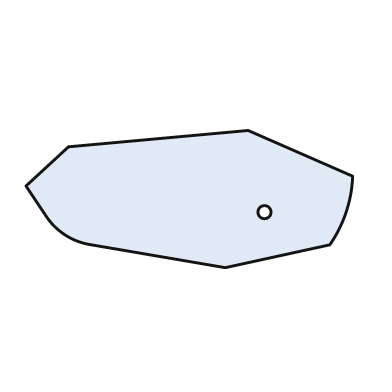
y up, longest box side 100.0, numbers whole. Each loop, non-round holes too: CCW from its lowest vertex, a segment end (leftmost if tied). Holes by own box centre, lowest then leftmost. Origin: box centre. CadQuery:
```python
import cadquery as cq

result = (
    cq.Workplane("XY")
    .moveTo(11.0, -21.0)
    .lineTo(43.0, -14.0)
    .threePointArc((48.0, -4.0), (50.0, 7.0))
    .lineTo(18.0, 21.0)
    .lineTo(-37.0, 16.0)
    .lineTo(-50.0, 4.0)
    .lineTo(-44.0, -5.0)
    .threePointArc((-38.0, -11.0), (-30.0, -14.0))
    .close()
    .moveTo(23.0, -4.0)
    .circle(2.0)
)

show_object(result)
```